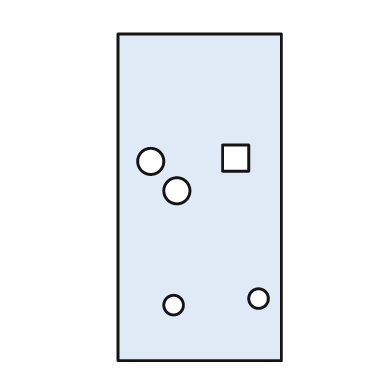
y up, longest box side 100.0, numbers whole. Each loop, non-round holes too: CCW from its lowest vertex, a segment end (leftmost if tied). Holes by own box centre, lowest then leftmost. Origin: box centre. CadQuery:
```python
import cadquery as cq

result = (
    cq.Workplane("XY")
    .moveTo(-25.0, -50.0)
    .lineTo(25.0, -50.0)
    .lineTo(25.0, 50.0)
    .lineTo(-25.0, 50.0)
    .close()
    .moveTo(-8.0, -33.0)
    .circle(3.0)
    .moveTo(18.0, -31.0)
    .circle(3.0)
    .moveTo(-7.0, 2.0)
    .circle(4.0)
    .moveTo(-15.0, 11.0)
    .circle(4.0)
    .moveTo(7.0, 8.0)
    .lineTo(15.0, 8.0)
    .lineTo(15.0, 16.0)
    .lineTo(7.0, 16.0)
    .close()
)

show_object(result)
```